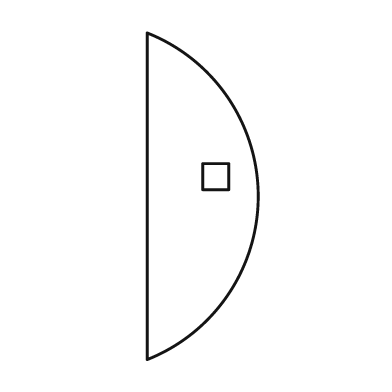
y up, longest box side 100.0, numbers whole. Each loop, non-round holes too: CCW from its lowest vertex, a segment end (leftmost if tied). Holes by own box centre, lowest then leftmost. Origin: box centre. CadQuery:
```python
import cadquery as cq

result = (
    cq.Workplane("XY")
    .moveTo(-17.0, -50.0)
    .threePointArc((17.0, 0.0), (-17.0, 50.0))
    .close()
    .moveTo(0.0, 2.0)
    .lineTo(8.0, 2.0)
    .lineTo(8.0, 10.0)
    .lineTo(0.0, 10.0)
    .close()
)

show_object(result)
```